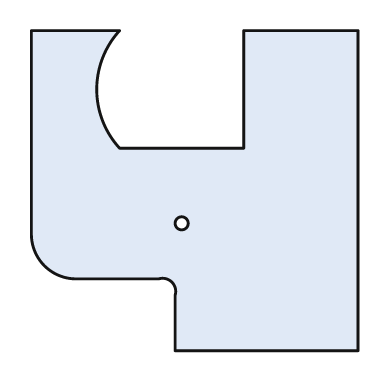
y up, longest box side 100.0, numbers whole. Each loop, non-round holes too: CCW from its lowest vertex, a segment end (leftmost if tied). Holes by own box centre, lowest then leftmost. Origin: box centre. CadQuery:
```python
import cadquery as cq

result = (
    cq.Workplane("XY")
    .moveTo(-6.0, -49.0)
    .lineTo(50.0, -49.0)
    .lineTo(50.0, 49.0)
    .lineTo(15.0, 49.0)
    .lineTo(15.0, 13.0)
    .lineTo(-23.0, 13.0)
    .threePointArc((-30.0, 31.0), (-23.0, 49.0))
    .lineTo(-50.0, 49.0)
    .lineTo(-50.0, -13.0)
    .threePointArc((-46.0, -23.0), (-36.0, -27.0))
    .lineTo(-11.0, -27.0)
    .threePointArc((-7.0, -28.0), (-6.0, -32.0))
    .close()
    .moveTo(-4.0, -10.0)
    .circle(2.0)
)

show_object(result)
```